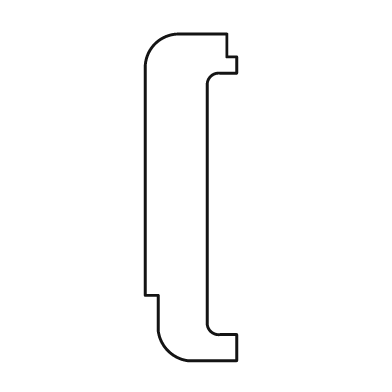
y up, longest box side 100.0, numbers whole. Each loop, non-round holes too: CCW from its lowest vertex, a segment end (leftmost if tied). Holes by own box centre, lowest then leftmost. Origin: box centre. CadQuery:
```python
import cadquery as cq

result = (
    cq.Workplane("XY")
    .moveTo(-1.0, -50.0)
    .lineTo(14.0, -50.0)
    .lineTo(14.0, -42.0)
    .lineTo(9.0, -42.0)
    .threePointArc((6.0, -41.0), (5.0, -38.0))
    .lineTo(5.0, 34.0)
    .threePointArc((6.0, 37.0), (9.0, 38.0))
    .lineTo(14.0, 38.0)
    .lineTo(14.0, 43.0)
    .lineTo(11.0, 43.0)
    .lineTo(11.0, 50.0)
    .lineTo(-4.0, 50.0)
    .threePointArc((-11.0, 47.0), (-14.0, 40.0))
    .lineTo(-14.0, -30.0)
    .lineTo(-10.0, -30.0)
    .lineTo(-10.0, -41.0)
    .threePointArc((-7.0, -47.0), (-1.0, -50.0))
    .close()
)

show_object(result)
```